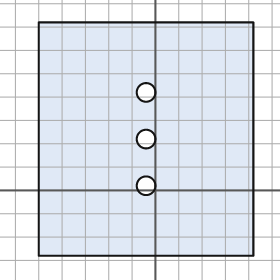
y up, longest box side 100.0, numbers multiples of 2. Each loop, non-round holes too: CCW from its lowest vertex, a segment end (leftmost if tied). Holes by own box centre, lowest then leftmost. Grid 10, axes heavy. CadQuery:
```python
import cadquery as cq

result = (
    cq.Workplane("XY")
    .moveTo(-50.0, -28.0)
    .lineTo(42.0, -28.0)
    .lineTo(42.0, 72.0)
    .lineTo(-50.0, 72.0)
    .close()
    .moveTo(-4.0, 2.0)
    .circle(4.0)
    .moveTo(-4.0, 22.0)
    .circle(4.0)
    .moveTo(-4.0, 42.0)
    .circle(4.0)
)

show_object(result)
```